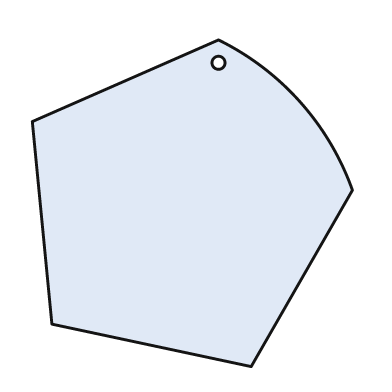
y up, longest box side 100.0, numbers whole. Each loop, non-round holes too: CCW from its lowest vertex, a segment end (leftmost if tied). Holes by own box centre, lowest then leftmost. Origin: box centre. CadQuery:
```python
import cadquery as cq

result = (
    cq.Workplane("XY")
    .moveTo(18.0, -50.0)
    .lineTo(49.0, 4.0)
    .threePointArc((33.0, 31.0), (8.0, 50.0))
    .lineTo(-49.0, 25.0)
    .lineTo(-43.0, -37.0)
    .close()
    .moveTo(8.0, 43.0)
    .circle(2.0)
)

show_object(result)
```